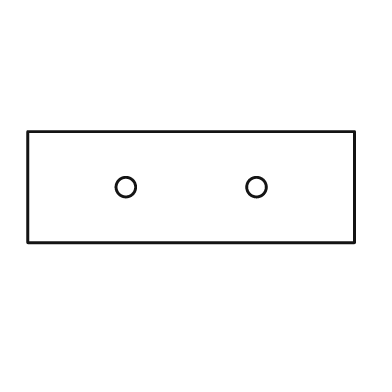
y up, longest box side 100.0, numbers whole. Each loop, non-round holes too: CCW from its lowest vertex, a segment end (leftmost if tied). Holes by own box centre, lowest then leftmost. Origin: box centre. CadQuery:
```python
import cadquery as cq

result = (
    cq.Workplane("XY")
    .moveTo(-50.0, -17.0)
    .lineTo(50.0, -17.0)
    .lineTo(50.0, 17.0)
    .lineTo(-50.0, 17.0)
    .close()
    .moveTo(-20.0, 0.0)
    .circle(3.0)
    .moveTo(20.0, 0.0)
    .circle(3.0)
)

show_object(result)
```